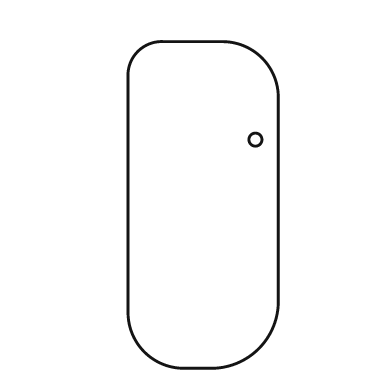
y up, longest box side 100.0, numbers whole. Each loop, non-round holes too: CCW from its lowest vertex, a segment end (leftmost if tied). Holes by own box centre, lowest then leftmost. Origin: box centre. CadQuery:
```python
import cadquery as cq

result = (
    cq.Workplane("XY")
    .moveTo(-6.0, -50.0)
    .lineTo(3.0, -50.0)
    .threePointArc((17.0, -44.0), (23.0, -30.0))
    .lineTo(23.0, 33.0)
    .threePointArc((18.0, 45.0), (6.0, 50.0))
    .lineTo(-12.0, 50.0)
    .threePointArc((-20.0, 47.0), (-23.0, 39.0))
    .lineTo(-23.0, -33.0)
    .threePointArc((-18.0, -45.0), (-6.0, -50.0))
    .close()
    .moveTo(16.0, 20.0)
    .circle(2.0)
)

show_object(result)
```